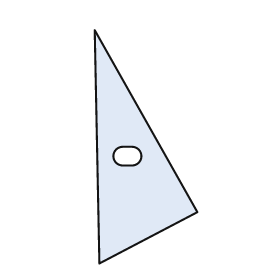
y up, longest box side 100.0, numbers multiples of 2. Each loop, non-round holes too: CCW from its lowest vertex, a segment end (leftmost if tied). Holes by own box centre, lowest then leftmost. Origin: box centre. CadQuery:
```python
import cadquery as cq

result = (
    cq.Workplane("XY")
    .moveTo(-20.0, -50.0)
    .lineTo(22.0, -28.0)
    .lineTo(-22.0, 50.0)
    .close()
    .moveTo(-10.0, -8.0)
    .lineTo(-6.0, -8.0)
    .threePointArc((-2.0, -4.0), (-6.0, 0.0))
    .lineTo(-10.0, 0.0)
    .threePointArc((-14.0, -4.0), (-10.0, -8.0))
    .close()
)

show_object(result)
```